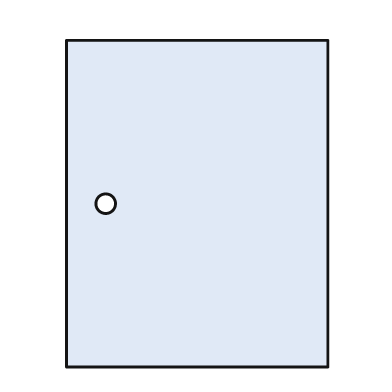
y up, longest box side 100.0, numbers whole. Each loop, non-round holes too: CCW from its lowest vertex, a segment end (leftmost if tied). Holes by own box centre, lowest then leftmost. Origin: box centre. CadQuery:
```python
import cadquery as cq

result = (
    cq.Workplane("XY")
    .moveTo(-40.0, -50.0)
    .lineTo(40.0, -50.0)
    .lineTo(40.0, 50.0)
    .lineTo(-40.0, 50.0)
    .close()
    .moveTo(-28.0, 0.0)
    .circle(3.0)
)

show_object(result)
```